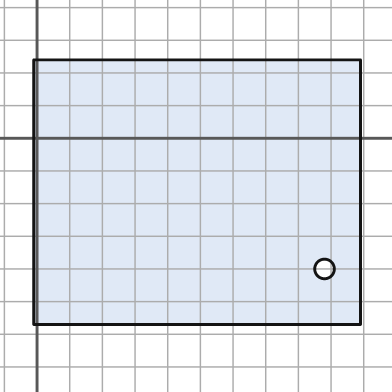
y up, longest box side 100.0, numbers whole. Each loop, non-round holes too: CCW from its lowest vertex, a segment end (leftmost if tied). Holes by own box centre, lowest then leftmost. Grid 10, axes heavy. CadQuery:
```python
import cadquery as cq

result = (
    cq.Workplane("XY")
    .moveTo(-1.0, -57.0)
    .lineTo(99.0, -57.0)
    .lineTo(99.0, 24.0)
    .lineTo(-1.0, 24.0)
    .close()
    .moveTo(88.0, -40.0)
    .circle(3.0)
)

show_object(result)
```